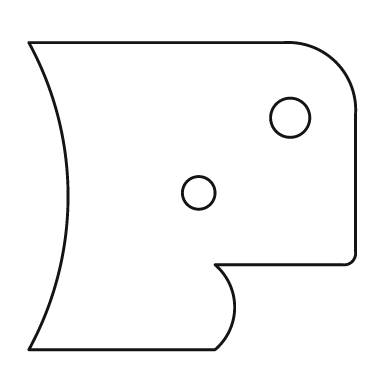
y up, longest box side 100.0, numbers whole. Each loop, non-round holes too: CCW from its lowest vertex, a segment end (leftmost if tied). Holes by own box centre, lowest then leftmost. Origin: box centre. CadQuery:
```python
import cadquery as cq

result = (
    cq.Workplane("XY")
    .moveTo(-50.0, -47.0)
    .lineTo(7.0, -47.0)
    .threePointArc((13.0, -34.0), (7.0, -21.0))
    .lineTo(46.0, -21.0)
    .threePointArc((49.0, -20.0), (50.0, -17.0))
    .lineTo(50.0, 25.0)
    .threePointArc((44.0, 41.0), (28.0, 47.0))
    .lineTo(-50.0, 47.0)
    .threePointArc((-38.0, 0.0), (-50.0, -47.0))
    .close()
    .moveTo(2.0, 1.0)
    .circle(5.0)
    .moveTo(30.0, 24.0)
    .circle(6.0)
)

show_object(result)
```